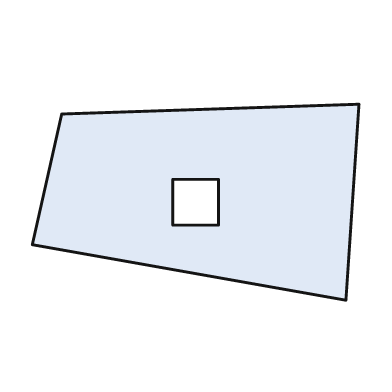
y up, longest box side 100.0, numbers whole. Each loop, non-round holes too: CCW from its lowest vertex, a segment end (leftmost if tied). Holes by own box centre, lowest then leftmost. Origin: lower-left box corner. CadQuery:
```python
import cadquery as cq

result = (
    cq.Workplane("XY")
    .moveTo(96.0, 0.0)
    .lineTo(100.0, 60.0)
    .lineTo(9.0, 57.0)
    .lineTo(0.0, 17.0)
    .close()
    .moveTo(43.0, 23.0)
    .lineTo(57.0, 23.0)
    .lineTo(57.0, 37.0)
    .lineTo(43.0, 37.0)
    .close()
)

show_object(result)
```